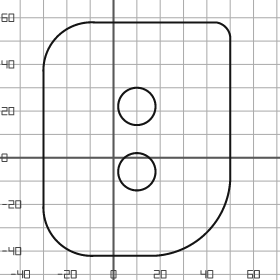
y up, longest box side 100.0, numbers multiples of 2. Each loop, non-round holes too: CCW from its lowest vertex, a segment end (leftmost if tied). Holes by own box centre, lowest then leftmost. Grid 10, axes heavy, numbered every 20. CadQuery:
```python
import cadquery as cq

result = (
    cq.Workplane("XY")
    .moveTo(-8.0, -42.0)
    .lineTo(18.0, -42.0)
    .threePointArc((40.0, -32.0), (50.0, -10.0))
    .lineTo(50.0, 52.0)
    .threePointArc((48.0, 56.0), (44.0, 58.0))
    .lineTo(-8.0, 58.0)
    .threePointArc((-24.0, 52.0), (-30.0, 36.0))
    .lineTo(-30.0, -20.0)
    .threePointArc((-24.0, -36.0), (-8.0, -42.0))
    .close()
    .moveTo(10.0, -6.0)
    .circle(8.0)
    .moveTo(10.0, 22.0)
    .circle(8.0)
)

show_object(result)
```